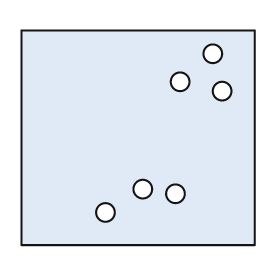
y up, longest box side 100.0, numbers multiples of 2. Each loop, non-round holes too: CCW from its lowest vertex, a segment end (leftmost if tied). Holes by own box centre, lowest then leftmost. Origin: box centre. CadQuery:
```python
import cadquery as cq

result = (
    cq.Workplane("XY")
    .moveTo(-50.0, -46.0)
    .lineTo(50.0, -46.0)
    .lineTo(50.0, 46.0)
    .lineTo(-50.0, 46.0)
    .close()
    .moveTo(-14.0, -32.0)
    .circle(4.0)
    .moveTo(16.0, -24.0)
    .circle(4.0)
    .moveTo(2.0, -22.0)
    .circle(4.0)
    .moveTo(36.0, 20.0)
    .circle(4.0)
    .moveTo(18.0, 24.0)
    .circle(4.0)
    .moveTo(32.0, 36.0)
    .circle(4.0)
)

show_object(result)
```